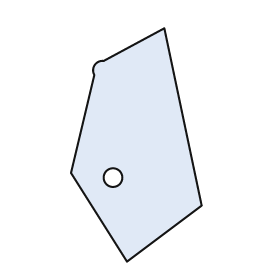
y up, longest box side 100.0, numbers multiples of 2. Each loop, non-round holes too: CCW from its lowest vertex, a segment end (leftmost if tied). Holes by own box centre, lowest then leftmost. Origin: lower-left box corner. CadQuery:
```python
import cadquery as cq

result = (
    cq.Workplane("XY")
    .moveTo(24.0, 0.0)
    .lineTo(56.0, 24.0)
    .lineTo(40.0, 100.0)
    .lineTo(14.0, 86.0)
    .threePointArc((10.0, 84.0), (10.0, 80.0))
    .lineTo(0.0, 38.0)
    .close()
    .moveTo(18.0, 36.0)
    .circle(4.0)
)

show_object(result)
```